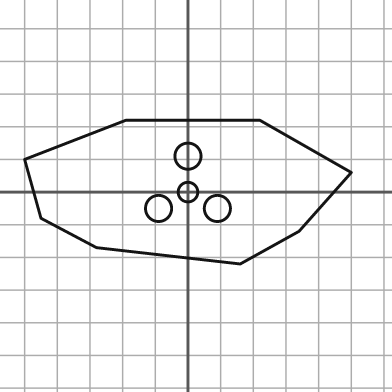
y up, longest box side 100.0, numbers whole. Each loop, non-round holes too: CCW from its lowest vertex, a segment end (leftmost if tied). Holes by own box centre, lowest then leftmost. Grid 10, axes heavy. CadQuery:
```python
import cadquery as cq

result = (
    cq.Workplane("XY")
    .moveTo(16.0, -22.0)
    .lineTo(34.0, -12.0)
    .lineTo(50.0, 6.0)
    .lineTo(22.0, 22.0)
    .lineTo(-19.0, 22.0)
    .lineTo(-50.0, 10.0)
    .lineTo(-45.0, -8.0)
    .lineTo(-28.0, -17.0)
    .close()
    .moveTo(-9.0, -5.0)
    .circle(4.0)
    .moveTo(9.0, -5.0)
    .circle(4.0)
    .moveTo(0.0, 0.0)
    .circle(3.0)
    .moveTo(0.0, 11.0)
    .circle(4.0)
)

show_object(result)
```